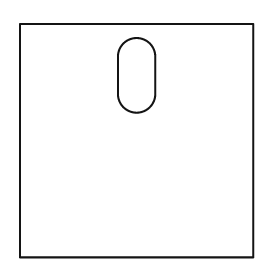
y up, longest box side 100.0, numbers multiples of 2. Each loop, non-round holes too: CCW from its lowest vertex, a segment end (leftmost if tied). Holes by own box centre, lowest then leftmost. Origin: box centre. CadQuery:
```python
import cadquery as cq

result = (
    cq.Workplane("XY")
    .moveTo(-50.0, -50.0)
    .lineTo(50.0, -50.0)
    .lineTo(50.0, 50.0)
    .lineTo(-50.0, 50.0)
    .close()
    .moveTo(-8.0, 20.0)
    .threePointArc((0.0, 12.0), (8.0, 20.0))
    .lineTo(8.0, 36.0)
    .threePointArc((0.0, 44.0), (-8.0, 36.0))
    .close()
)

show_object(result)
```